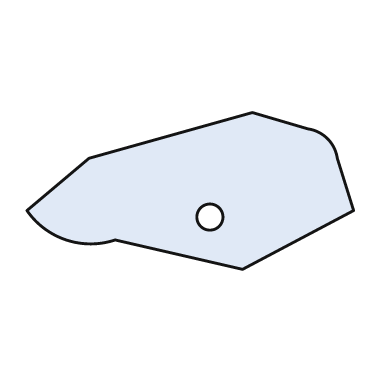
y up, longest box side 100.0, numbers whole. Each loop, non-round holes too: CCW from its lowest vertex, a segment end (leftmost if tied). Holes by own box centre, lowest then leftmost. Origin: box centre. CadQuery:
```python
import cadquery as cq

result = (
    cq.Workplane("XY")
    .moveTo(16.0, -24.0)
    .lineTo(50.0, -6.0)
    .lineTo(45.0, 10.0)
    .threePointArc((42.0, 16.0), (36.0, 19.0))
    .lineTo(19.0, 24.0)
    .lineTo(-31.0, 10.0)
    .lineTo(-50.0, -6.0)
    .threePointArc((-38.0, -15.0), (-23.0, -15.0))
    .close()
    .moveTo(6.0, -8.0)
    .circle(4.0)
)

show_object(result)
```